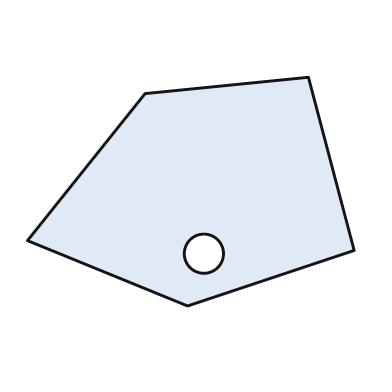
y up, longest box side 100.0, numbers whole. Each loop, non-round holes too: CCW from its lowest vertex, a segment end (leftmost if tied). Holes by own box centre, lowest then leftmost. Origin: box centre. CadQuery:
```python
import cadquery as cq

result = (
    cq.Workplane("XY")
    .moveTo(-1.0, -35.0)
    .lineTo(50.0, -18.0)
    .lineTo(36.0, 35.0)
    .lineTo(-14.0, 30.0)
    .lineTo(-50.0, -15.0)
    .close()
    .moveTo(4.0, -19.0)
    .circle(6.0)
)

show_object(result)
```